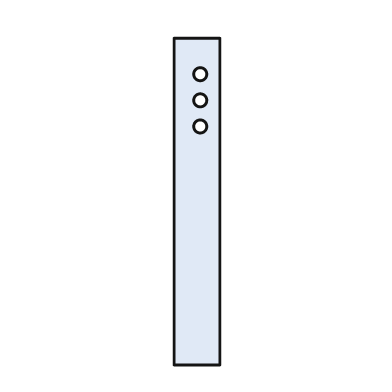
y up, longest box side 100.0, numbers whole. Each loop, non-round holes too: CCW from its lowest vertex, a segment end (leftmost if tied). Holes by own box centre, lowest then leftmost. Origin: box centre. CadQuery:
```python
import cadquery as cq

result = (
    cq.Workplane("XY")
    .moveTo(-7.0, -50.0)
    .lineTo(7.0, -50.0)
    .lineTo(7.0, 50.0)
    .lineTo(-7.0, 50.0)
    .close()
    .moveTo(1.0, 23.0)
    .circle(2.0)
    .moveTo(1.0, 31.0)
    .circle(2.0)
    .moveTo(1.0, 39.0)
    .circle(2.0)
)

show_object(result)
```